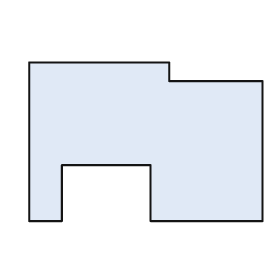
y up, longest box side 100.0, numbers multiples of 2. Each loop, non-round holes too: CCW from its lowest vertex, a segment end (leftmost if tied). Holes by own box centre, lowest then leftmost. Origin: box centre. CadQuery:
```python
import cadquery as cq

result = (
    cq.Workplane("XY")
    .moveTo(-50.0, -34.0)
    .lineTo(-36.0, -34.0)
    .lineTo(-36.0, -10.0)
    .lineTo(2.0, -10.0)
    .lineTo(2.0, -34.0)
    .lineTo(50.0, -34.0)
    .lineTo(50.0, 26.0)
    .lineTo(10.0, 26.0)
    .lineTo(10.0, 34.0)
    .lineTo(-50.0, 34.0)
    .close()
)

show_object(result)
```